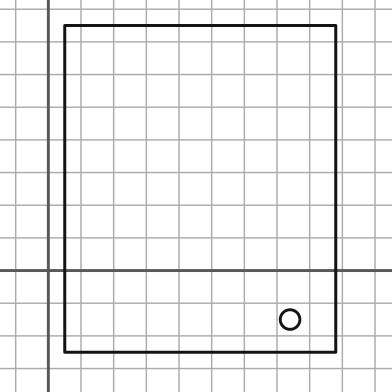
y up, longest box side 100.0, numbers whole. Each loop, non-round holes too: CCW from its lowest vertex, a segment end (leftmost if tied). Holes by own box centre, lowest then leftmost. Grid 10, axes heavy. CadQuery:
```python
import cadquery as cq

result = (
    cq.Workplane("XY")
    .moveTo(5.0, -25.0)
    .lineTo(88.0, -25.0)
    .lineTo(88.0, 75.0)
    .lineTo(5.0, 75.0)
    .close()
    .moveTo(74.0, -15.0)
    .circle(3.0)
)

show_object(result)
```